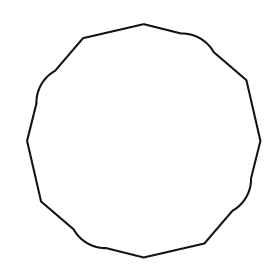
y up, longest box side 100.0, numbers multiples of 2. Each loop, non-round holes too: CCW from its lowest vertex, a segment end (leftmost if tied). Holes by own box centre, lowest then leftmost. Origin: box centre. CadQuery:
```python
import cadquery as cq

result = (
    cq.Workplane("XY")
    .moveTo(0.0, -50.0)
    .lineTo(26.0, -44.0)
    .lineTo(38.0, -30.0)
    .threePointArc((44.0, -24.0), (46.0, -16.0))
    .lineTo(50.0, 0.0)
    .lineTo(44.0, 26.0)
    .lineTo(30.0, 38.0)
    .threePointArc((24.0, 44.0), (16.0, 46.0))
    .lineTo(0.0, 50.0)
    .lineTo(-26.0, 44.0)
    .lineTo(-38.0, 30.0)
    .threePointArc((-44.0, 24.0), (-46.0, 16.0))
    .lineTo(-50.0, 0.0)
    .lineTo(-44.0, -26.0)
    .lineTo(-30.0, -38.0)
    .threePointArc((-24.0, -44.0), (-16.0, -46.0))
    .close()
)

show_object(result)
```